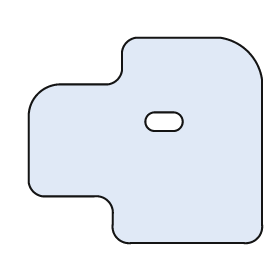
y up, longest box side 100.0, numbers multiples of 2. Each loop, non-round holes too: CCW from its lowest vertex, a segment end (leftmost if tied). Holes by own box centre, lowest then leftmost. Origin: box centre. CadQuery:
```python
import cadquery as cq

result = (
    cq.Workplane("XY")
    .moveTo(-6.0, -44.0)
    .lineTo(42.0, -44.0)
    .threePointArc((48.0, -42.0), (50.0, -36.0))
    .lineTo(50.0, 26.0)
    .threePointArc((44.0, 38.0), (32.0, 44.0))
    .lineTo(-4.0, 44.0)
    .threePointArc((-8.0, 42.0), (-10.0, 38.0))
    .lineTo(-10.0, 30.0)
    .threePointArc((-12.0, 26.0), (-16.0, 24.0))
    .lineTo(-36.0, 24.0)
    .threePointArc((-46.0, 20.0), (-50.0, 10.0))
    .lineTo(-50.0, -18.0)
    .threePointArc((-48.0, -22.0), (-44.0, -24.0))
    .lineTo(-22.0, -24.0)
    .threePointArc((-16.0, -26.0), (-14.0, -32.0))
    .lineTo(-14.0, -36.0)
    .threePointArc((-12.0, -42.0), (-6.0, -44.0))
    .close()
    .moveTo(4.0, 4.0)
    .lineTo(12.0, 4.0)
    .threePointArc((16.0, 8.0), (12.0, 12.0))
    .lineTo(4.0, 12.0)
    .threePointArc((0.0, 8.0), (4.0, 4.0))
    .close()
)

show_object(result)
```